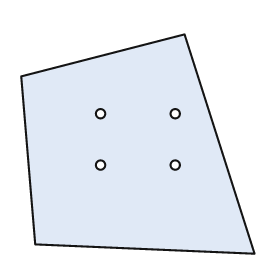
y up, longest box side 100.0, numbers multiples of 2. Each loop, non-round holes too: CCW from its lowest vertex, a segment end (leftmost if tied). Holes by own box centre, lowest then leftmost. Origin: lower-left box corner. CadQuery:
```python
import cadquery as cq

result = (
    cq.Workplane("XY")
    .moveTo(100.0, 0.0)
    .lineTo(70.0, 94.0)
    .lineTo(0.0, 76.0)
    .lineTo(6.0, 4.0)
    .close()
    .moveTo(34.0, 38.0)
    .circle(2.0)
    .moveTo(66.0, 38.0)
    .circle(2.0)
    .moveTo(34.0, 60.0)
    .circle(2.0)
    .moveTo(66.0, 60.0)
    .circle(2.0)
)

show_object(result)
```